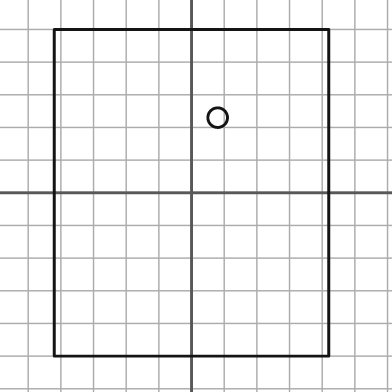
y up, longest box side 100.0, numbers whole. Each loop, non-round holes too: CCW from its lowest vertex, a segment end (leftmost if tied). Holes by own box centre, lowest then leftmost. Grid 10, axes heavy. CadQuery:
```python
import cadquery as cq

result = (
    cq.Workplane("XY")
    .moveTo(-42.0, -50.0)
    .lineTo(42.0, -50.0)
    .lineTo(42.0, 50.0)
    .lineTo(-42.0, 50.0)
    .close()
    .moveTo(8.0, 23.0)
    .circle(3.0)
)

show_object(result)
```